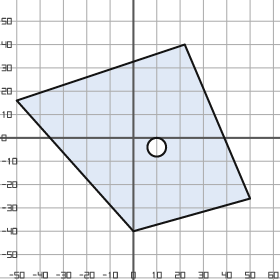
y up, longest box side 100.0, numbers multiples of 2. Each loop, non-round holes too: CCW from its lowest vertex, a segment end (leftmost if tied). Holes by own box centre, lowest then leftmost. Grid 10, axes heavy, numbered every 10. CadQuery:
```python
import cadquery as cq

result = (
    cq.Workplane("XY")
    .moveTo(0.0, -40.0)
    .lineTo(50.0, -26.0)
    .lineTo(22.0, 40.0)
    .lineTo(-50.0, 16.0)
    .close()
    .moveTo(10.0, -4.0)
    .circle(4.0)
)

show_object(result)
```